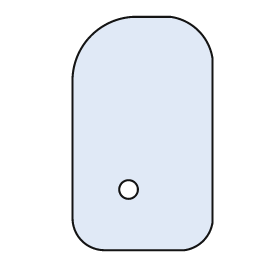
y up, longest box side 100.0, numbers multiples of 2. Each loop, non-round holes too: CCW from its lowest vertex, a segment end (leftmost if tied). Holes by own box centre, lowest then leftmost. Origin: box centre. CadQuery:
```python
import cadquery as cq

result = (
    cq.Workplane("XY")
    .moveTo(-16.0, -50.0)
    .lineTo(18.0, -50.0)
    .threePointArc((26.0, -46.0), (30.0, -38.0))
    .lineTo(30.0, 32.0)
    .threePointArc((24.0, 44.0), (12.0, 50.0))
    .lineTo(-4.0, 50.0)
    .threePointArc((-22.0, 42.0), (-30.0, 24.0))
    .lineTo(-30.0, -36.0)
    .threePointArc((-26.0, -46.0), (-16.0, -50.0))
    .close()
    .moveTo(-6.0, -24.0)
    .circle(4.0)
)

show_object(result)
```